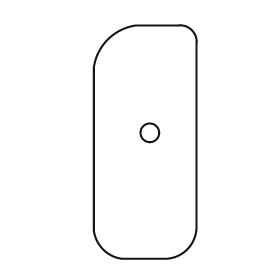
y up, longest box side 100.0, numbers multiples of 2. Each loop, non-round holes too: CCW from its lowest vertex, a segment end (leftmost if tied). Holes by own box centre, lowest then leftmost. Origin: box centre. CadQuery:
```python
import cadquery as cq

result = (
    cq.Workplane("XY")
    .moveTo(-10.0, -50.0)
    .lineTo(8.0, -50.0)
    .threePointArc((18.0, -46.0), (22.0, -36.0))
    .lineTo(22.0, 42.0)
    .threePointArc((20.0, 48.0), (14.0, 50.0))
    .lineTo(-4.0, 50.0)
    .threePointArc((-16.0, 44.0), (-22.0, 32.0))
    .lineTo(-22.0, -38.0)
    .threePointArc((-18.0, -46.0), (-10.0, -50.0))
    .close()
    .moveTo(2.0, 4.0)
    .circle(4.0)
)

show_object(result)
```